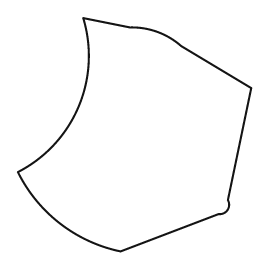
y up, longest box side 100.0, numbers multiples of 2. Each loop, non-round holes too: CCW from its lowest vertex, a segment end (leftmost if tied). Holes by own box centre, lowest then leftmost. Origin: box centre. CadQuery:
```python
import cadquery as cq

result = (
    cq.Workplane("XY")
    .moveTo(-6.0, -50.0)
    .lineTo(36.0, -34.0)
    .threePointArc((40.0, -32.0), (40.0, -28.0))
    .lineTo(50.0, 20.0)
    .lineTo(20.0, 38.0)
    .threePointArc((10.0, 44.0), (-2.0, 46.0))
    .lineTo(-22.0, 50.0)
    .threePointArc((-24.0, 12.0), (-50.0, -16.0))
    .threePointArc((-32.0, -38.0), (-6.0, -50.0))
    .close()
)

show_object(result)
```